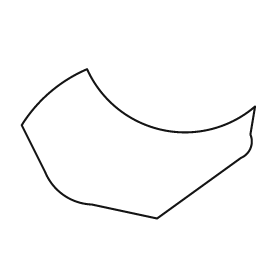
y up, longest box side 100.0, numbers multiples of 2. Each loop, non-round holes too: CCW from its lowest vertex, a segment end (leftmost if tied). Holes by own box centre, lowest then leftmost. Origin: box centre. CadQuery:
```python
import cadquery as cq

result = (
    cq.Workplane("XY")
    .moveTo(8.0, -32.0)
    .lineTo(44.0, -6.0)
    .threePointArc((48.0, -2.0), (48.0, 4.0))
    .lineTo(50.0, 16.0)
    .threePointArc((10.0, 6.0), (-22.0, 32.0))
    .threePointArc((-38.0, 22.0), (-50.0, 8.0))
    .lineTo(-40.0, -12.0)
    .threePointArc((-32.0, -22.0), (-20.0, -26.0))
    .close()
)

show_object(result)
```